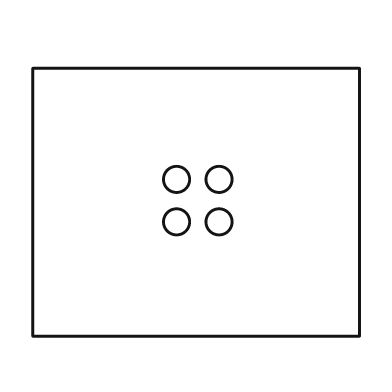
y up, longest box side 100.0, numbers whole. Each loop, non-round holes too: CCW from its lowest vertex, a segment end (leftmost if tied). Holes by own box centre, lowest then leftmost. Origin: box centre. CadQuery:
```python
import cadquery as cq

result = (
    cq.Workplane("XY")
    .moveTo(-50.0, -41.0)
    .lineTo(50.0, -41.0)
    .lineTo(50.0, 41.0)
    .lineTo(-50.0, 41.0)
    .close()
    .moveTo(-6.0, -6.0)
    .circle(4.0)
    .moveTo(7.0, -6.0)
    .circle(4.0)
    .moveTo(-6.0, 7.0)
    .circle(4.0)
    .moveTo(7.0, 7.0)
    .circle(4.0)
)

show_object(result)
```